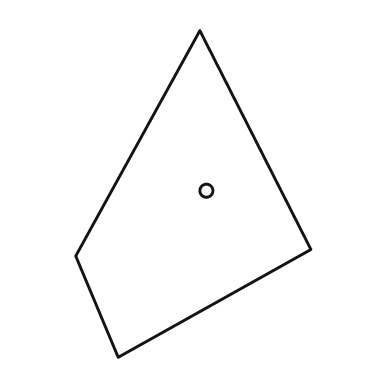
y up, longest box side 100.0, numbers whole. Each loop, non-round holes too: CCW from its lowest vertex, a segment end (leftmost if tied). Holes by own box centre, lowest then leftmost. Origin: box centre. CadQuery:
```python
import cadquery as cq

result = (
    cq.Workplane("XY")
    .moveTo(-23.0, -50.0)
    .lineTo(36.0, -17.0)
    .lineTo(2.0, 50.0)
    .lineTo(-36.0, -19.0)
    .close()
    .moveTo(4.0, 1.0)
    .circle(2.0)
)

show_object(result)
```